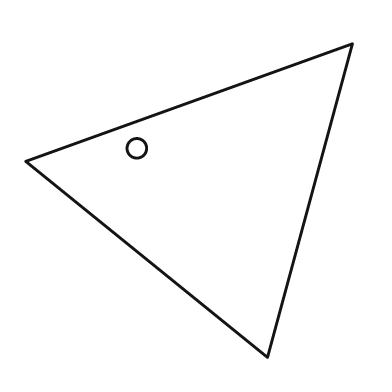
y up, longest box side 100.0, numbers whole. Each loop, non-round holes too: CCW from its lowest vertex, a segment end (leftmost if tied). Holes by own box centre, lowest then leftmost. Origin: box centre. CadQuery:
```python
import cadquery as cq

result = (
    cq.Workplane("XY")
    .moveTo(24.0, -48.0)
    .lineTo(50.0, 48.0)
    .lineTo(-50.0, 12.0)
    .close()
    .moveTo(-16.0, 16.0)
    .circle(3.0)
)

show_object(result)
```